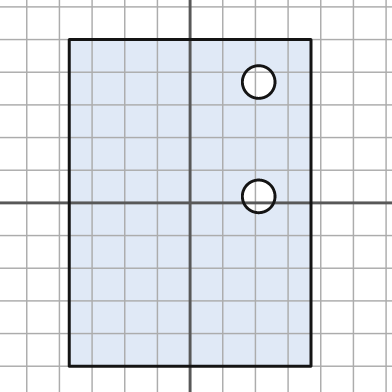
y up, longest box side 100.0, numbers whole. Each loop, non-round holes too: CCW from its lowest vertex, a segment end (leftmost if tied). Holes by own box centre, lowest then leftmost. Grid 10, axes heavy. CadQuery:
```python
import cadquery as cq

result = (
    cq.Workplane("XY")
    .moveTo(-37.0, -50.0)
    .lineTo(37.0, -50.0)
    .lineTo(37.0, 50.0)
    .lineTo(-37.0, 50.0)
    .close()
    .moveTo(21.0, 2.0)
    .circle(5.0)
    .moveTo(21.0, 37.0)
    .circle(5.0)
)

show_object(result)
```